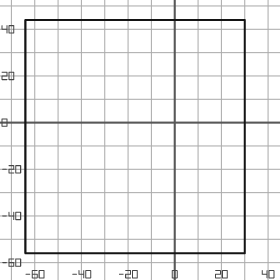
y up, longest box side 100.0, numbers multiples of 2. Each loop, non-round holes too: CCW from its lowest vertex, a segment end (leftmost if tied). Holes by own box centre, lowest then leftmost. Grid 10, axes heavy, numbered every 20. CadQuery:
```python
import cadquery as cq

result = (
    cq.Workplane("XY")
    .moveTo(-64.0, -56.0)
    .lineTo(30.0, -56.0)
    .lineTo(30.0, 44.0)
    .lineTo(-64.0, 44.0)
    .close()
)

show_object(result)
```